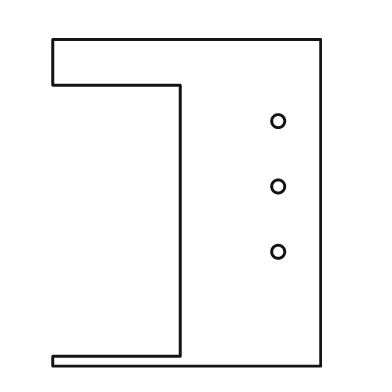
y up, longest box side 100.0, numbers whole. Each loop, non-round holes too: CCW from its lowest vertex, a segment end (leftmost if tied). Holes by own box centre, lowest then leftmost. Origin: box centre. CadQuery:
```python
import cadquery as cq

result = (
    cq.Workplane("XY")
    .moveTo(-41.0, -50.0)
    .lineTo(41.0, -50.0)
    .lineTo(41.0, 50.0)
    .lineTo(-41.0, 50.0)
    .lineTo(-41.0, 36.0)
    .lineTo(-2.0, 36.0)
    .lineTo(-2.0, -47.0)
    .lineTo(-41.0, -47.0)
    .close()
    .moveTo(28.0, -15.0)
    .circle(2.0)
    .moveTo(28.0, 5.0)
    .circle(2.0)
    .moveTo(28.0, 25.0)
    .circle(2.0)
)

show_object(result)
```